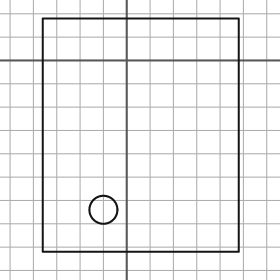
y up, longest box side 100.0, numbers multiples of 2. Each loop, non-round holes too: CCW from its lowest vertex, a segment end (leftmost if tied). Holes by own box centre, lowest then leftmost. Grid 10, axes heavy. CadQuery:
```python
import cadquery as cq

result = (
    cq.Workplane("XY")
    .moveTo(-36.0, -82.0)
    .lineTo(48.0, -82.0)
    .lineTo(48.0, 18.0)
    .lineTo(-36.0, 18.0)
    .close()
    .moveTo(-10.0, -64.0)
    .circle(6.0)
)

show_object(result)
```